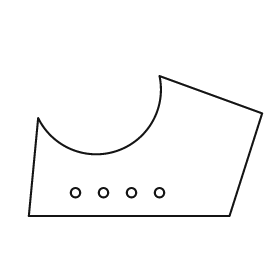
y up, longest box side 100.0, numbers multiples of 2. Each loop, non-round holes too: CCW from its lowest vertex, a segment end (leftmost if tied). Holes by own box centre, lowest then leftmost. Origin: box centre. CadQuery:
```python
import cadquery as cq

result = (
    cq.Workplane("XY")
    .moveTo(-50.0, -30.0)
    .lineTo(36.0, -30.0)
    .lineTo(50.0, 14.0)
    .lineTo(6.0, 30.0)
    .threePointArc((-12.0, -2.0), (-46.0, 12.0))
    .close()
    .moveTo(-30.0, -20.0)
    .circle(2.0)
    .moveTo(-18.0, -20.0)
    .circle(2.0)
    .moveTo(-6.0, -20.0)
    .circle(2.0)
    .moveTo(6.0, -20.0)
    .circle(2.0)
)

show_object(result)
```